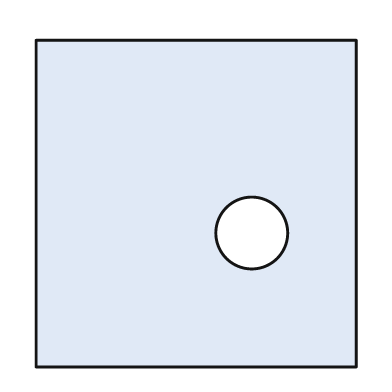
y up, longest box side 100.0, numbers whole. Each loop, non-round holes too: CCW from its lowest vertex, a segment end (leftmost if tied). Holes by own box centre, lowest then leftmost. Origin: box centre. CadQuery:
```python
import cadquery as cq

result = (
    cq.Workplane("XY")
    .moveTo(-49.0, -50.0)
    .lineTo(49.0, -50.0)
    .lineTo(49.0, 50.0)
    .lineTo(-49.0, 50.0)
    .close()
    .moveTo(17.0, -9.0)
    .circle(11.0)
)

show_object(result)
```